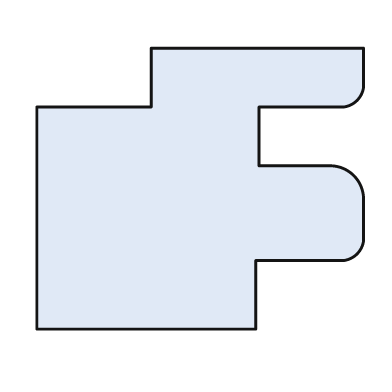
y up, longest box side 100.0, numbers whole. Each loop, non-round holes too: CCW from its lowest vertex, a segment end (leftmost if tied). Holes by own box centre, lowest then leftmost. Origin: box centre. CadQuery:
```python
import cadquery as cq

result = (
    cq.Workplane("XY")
    .moveTo(-50.0, -43.0)
    .lineTo(17.0, -43.0)
    .lineTo(17.0, -22.0)
    .lineTo(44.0, -22.0)
    .threePointArc((48.0, -20.0), (50.0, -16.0))
    .lineTo(50.0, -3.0)
    .threePointArc((47.0, 4.0), (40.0, 7.0))
    .lineTo(18.0, 7.0)
    .lineTo(18.0, 25.0)
    .lineTo(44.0, 25.0)
    .threePointArc((48.0, 27.0), (50.0, 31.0))
    .lineTo(50.0, 43.0)
    .lineTo(-15.0, 43.0)
    .lineTo(-15.0, 25.0)
    .lineTo(-50.0, 25.0)
    .close()
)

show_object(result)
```